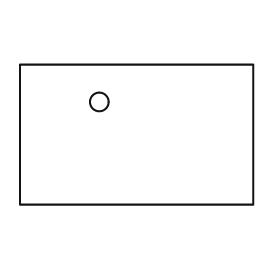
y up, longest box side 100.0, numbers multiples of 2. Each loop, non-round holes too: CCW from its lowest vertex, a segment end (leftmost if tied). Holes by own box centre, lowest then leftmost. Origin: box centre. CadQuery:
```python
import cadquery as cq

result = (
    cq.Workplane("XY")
    .moveTo(-50.0, -30.0)
    .lineTo(50.0, -30.0)
    .lineTo(50.0, 30.0)
    .lineTo(-50.0, 30.0)
    .close()
    .moveTo(-16.0, 14.0)
    .circle(4.0)
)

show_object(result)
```